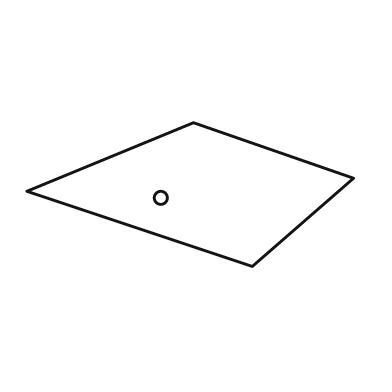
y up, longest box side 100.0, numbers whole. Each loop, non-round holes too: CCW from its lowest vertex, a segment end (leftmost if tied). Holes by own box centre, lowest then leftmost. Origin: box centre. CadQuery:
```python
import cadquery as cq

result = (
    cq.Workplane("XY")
    .moveTo(19.0, -22.0)
    .lineTo(50.0, 5.0)
    .lineTo(1.0, 22.0)
    .lineTo(-50.0, 1.0)
    .close()
    .moveTo(-9.0, -1.0)
    .circle(2.0)
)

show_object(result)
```